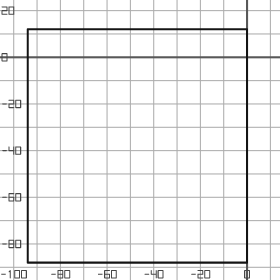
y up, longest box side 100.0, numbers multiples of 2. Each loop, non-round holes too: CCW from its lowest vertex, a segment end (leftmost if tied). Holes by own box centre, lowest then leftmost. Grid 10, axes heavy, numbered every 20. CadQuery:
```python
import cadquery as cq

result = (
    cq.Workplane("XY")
    .moveTo(-94.0, -88.0)
    .lineTo(0.0, -88.0)
    .lineTo(0.0, 12.0)
    .lineTo(-94.0, 12.0)
    .close()
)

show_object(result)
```